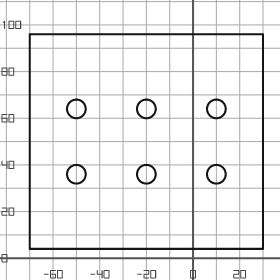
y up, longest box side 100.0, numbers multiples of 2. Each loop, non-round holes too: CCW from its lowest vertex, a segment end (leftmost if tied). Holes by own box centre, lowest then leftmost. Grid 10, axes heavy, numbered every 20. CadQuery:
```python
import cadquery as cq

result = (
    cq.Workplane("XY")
    .moveTo(-70.0, 4.0)
    .lineTo(30.0, 4.0)
    .lineTo(30.0, 96.0)
    .lineTo(-70.0, 96.0)
    .close()
    .moveTo(-50.0, 36.0)
    .circle(4.0)
    .moveTo(-20.0, 36.0)
    .circle(4.0)
    .moveTo(10.0, 36.0)
    .circle(4.0)
    .moveTo(-50.0, 64.0)
    .circle(4.0)
    .moveTo(-20.0, 64.0)
    .circle(4.0)
    .moveTo(10.0, 64.0)
    .circle(4.0)
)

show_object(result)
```